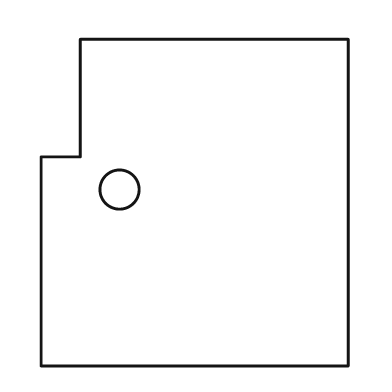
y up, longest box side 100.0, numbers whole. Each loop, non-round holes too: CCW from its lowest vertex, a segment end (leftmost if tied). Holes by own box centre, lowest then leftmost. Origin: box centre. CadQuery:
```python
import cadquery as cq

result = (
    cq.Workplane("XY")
    .moveTo(-47.0, -50.0)
    .lineTo(47.0, -50.0)
    .lineTo(47.0, 50.0)
    .lineTo(-35.0, 50.0)
    .lineTo(-35.0, 14.0)
    .lineTo(-47.0, 14.0)
    .close()
    .moveTo(-23.0, 4.0)
    .circle(6.0)
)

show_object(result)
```